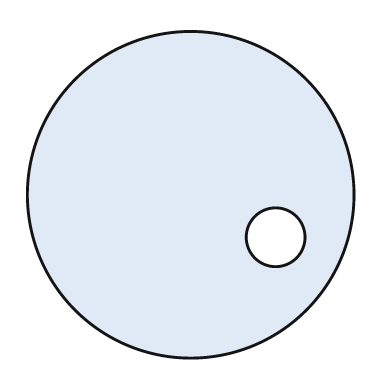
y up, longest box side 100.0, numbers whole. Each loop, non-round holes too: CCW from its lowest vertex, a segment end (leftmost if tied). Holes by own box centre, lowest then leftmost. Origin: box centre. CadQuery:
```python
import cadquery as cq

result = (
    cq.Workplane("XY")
    .moveTo(0.0, 0.0)
    .circle(50.0)
    .moveTo(26.0, -13.0)
    .circle(9.0)
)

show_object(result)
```